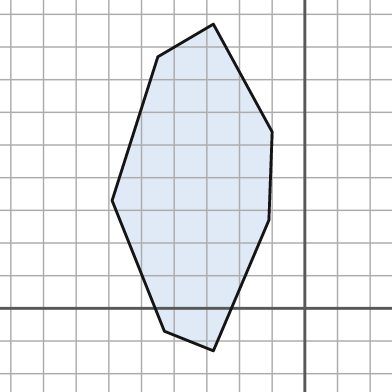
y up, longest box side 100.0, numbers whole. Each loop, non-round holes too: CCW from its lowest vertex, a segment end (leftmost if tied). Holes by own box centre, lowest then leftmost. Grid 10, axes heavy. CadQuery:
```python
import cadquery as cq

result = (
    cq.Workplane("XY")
    .moveTo(-28.0, -13.0)
    .lineTo(-11.0, 27.0)
    .lineTo(-10.0, 54.0)
    .lineTo(-28.0, 87.0)
    .lineTo(-45.0, 77.0)
    .lineTo(-59.0, 33.0)
    .lineTo(-43.0, -7.0)
    .close()
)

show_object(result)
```